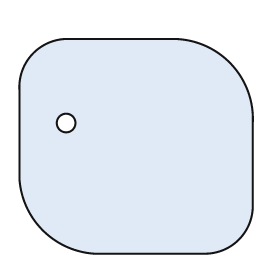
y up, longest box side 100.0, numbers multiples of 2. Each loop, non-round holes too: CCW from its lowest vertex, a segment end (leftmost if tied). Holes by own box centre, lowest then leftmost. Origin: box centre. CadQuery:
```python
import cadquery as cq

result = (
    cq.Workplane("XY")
    .moveTo(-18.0, -46.0)
    .lineTo(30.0, -46.0)
    .threePointArc((44.0, -40.0), (50.0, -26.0))
    .lineTo(50.0, 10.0)
    .threePointArc((40.0, 36.0), (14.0, 46.0))
    .lineTo(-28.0, 46.0)
    .threePointArc((-44.0, 40.0), (-50.0, 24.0))
    .lineTo(-50.0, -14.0)
    .threePointArc((-40.0, -36.0), (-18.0, -46.0))
    .close()
    .moveTo(-30.0, 10.0)
    .circle(4.0)
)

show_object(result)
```